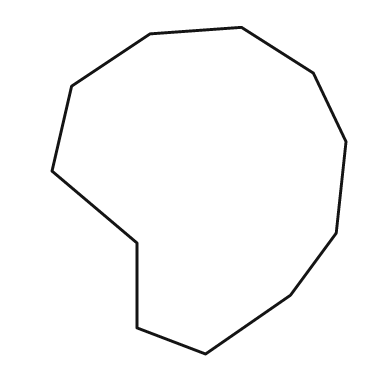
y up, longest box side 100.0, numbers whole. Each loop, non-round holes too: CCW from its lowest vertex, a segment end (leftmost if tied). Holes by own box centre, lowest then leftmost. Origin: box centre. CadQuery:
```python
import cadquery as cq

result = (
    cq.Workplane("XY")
    .moveTo(2.0, -50.0)
    .lineTo(28.0, -32.0)
    .lineTo(42.0, -13.0)
    .lineTo(45.0, 15.0)
    .lineTo(35.0, 36.0)
    .lineTo(13.0, 50.0)
    .lineTo(-15.0, 48.0)
    .lineTo(-39.0, 32.0)
    .lineTo(-45.0, 6.0)
    .lineTo(-19.0, -16.0)
    .lineTo(-19.0, -42.0)
    .close()
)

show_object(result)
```